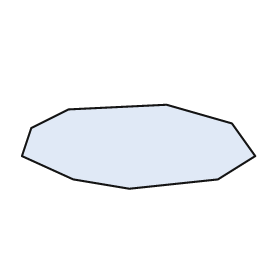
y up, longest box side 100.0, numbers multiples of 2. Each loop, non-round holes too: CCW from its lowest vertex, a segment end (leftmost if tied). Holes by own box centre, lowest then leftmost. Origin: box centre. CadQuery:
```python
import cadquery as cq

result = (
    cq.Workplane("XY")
    .moveTo(-4.0, -18.0)
    .lineTo(34.0, -14.0)
    .lineTo(50.0, -4.0)
    .lineTo(40.0, 10.0)
    .lineTo(12.0, 18.0)
    .lineTo(-30.0, 16.0)
    .lineTo(-46.0, 8.0)
    .lineTo(-50.0, -4.0)
    .lineTo(-28.0, -14.0)
    .close()
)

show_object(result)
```